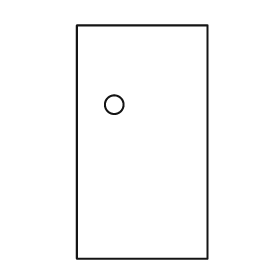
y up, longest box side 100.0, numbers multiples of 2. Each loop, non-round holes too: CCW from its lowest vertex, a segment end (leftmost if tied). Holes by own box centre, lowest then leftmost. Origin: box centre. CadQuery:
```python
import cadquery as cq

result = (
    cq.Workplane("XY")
    .moveTo(-28.0, -50.0)
    .lineTo(28.0, -50.0)
    .lineTo(28.0, 50.0)
    .lineTo(-28.0, 50.0)
    .close()
    .moveTo(-12.0, 16.0)
    .circle(4.0)
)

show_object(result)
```